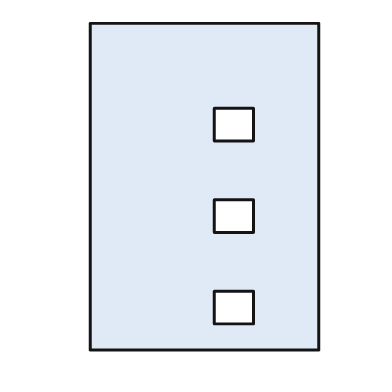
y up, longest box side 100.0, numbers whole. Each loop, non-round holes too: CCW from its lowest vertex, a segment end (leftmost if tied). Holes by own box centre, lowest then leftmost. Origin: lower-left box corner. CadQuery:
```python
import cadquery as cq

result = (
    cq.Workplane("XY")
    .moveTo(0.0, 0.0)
    .lineTo(70.0, 0.0)
    .lineTo(70.0, 100.0)
    .lineTo(0.0, 100.0)
    .close()
    .moveTo(38.0, 8.0)
    .lineTo(50.0, 8.0)
    .lineTo(50.0, 18.0)
    .lineTo(38.0, 18.0)
    .close()
    .moveTo(38.0, 36.0)
    .lineTo(50.0, 36.0)
    .lineTo(50.0, 46.0)
    .lineTo(38.0, 46.0)
    .close()
    .moveTo(38.0, 64.0)
    .lineTo(50.0, 64.0)
    .lineTo(50.0, 74.0)
    .lineTo(38.0, 74.0)
    .close()
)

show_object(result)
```